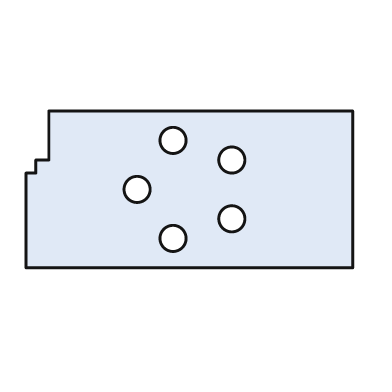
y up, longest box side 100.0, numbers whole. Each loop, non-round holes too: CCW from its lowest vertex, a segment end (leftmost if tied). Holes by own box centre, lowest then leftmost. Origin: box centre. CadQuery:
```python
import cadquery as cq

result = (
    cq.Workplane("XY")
    .moveTo(-50.0, -24.0)
    .lineTo(50.0, -24.0)
    .lineTo(50.0, 24.0)
    .lineTo(-43.0, 24.0)
    .lineTo(-43.0, 9.0)
    .lineTo(-47.0, 9.0)
    .lineTo(-47.0, 5.0)
    .lineTo(-50.0, 5.0)
    .close()
    .moveTo(-5.0, -15.0)
    .circle(4.0)
    .moveTo(13.0, -9.0)
    .circle(4.0)
    .moveTo(-16.0, 0.0)
    .circle(4.0)
    .moveTo(13.0, 9.0)
    .circle(4.0)
    .moveTo(-5.0, 15.0)
    .circle(4.0)
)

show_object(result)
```